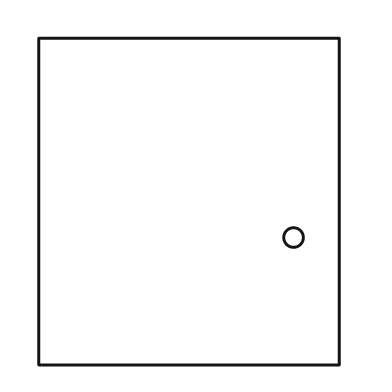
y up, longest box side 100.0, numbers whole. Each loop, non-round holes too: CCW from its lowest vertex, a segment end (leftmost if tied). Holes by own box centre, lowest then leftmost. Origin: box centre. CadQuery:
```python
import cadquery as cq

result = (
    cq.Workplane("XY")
    .moveTo(-46.0, -50.0)
    .lineTo(46.0, -50.0)
    .lineTo(46.0, 50.0)
    .lineTo(-46.0, 50.0)
    .close()
    .moveTo(32.0, -11.0)
    .circle(3.0)
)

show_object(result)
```